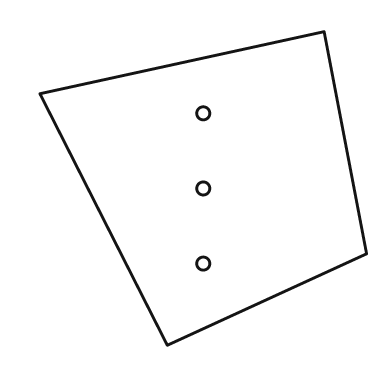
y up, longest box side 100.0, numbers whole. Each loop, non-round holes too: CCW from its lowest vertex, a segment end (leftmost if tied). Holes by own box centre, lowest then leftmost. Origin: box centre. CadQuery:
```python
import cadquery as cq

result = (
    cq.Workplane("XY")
    .moveTo(-11.0, -48.0)
    .lineTo(50.0, -20.0)
    .lineTo(37.0, 48.0)
    .lineTo(-50.0, 29.0)
    .close()
    .moveTo(0.0, -23.0)
    .circle(2.0)
    .moveTo(0.0, 0.0)
    .circle(2.0)
    .moveTo(0.0, 23.0)
    .circle(2.0)
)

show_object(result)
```